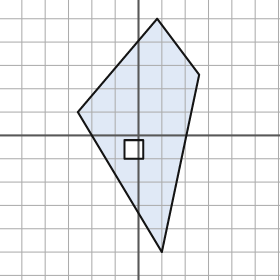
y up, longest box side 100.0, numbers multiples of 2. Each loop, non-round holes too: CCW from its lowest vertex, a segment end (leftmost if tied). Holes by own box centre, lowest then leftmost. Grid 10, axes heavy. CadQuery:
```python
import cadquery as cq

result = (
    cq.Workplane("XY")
    .moveTo(10.0, -50.0)
    .lineTo(26.0, 26.0)
    .lineTo(8.0, 50.0)
    .lineTo(-26.0, 10.0)
    .close()
    .moveTo(-6.0, -10.0)
    .lineTo(2.0, -10.0)
    .lineTo(2.0, -2.0)
    .lineTo(-6.0, -2.0)
    .close()
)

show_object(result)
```